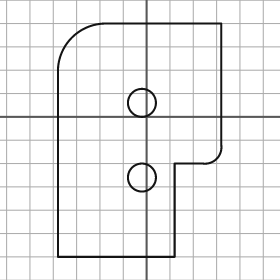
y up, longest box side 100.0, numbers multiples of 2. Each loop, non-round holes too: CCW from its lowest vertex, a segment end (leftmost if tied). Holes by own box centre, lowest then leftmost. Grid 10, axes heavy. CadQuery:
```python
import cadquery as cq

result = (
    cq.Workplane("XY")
    .moveTo(-38.0, -60.0)
    .lineTo(12.0, -60.0)
    .lineTo(12.0, -20.0)
    .lineTo(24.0, -20.0)
    .threePointArc((30.0, -18.0), (32.0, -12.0))
    .lineTo(32.0, 40.0)
    .lineTo(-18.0, 40.0)
    .threePointArc((-32.0, 34.0), (-38.0, 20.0))
    .close()
    .moveTo(-2.0, -26.0)
    .circle(6.0)
    .moveTo(-2.0, 6.0)
    .circle(6.0)
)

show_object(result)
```